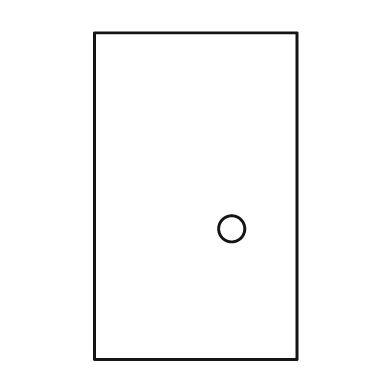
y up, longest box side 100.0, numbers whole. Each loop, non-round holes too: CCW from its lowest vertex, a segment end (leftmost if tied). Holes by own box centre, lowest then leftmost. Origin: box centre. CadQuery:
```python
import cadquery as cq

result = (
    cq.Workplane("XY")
    .moveTo(-31.0, -50.0)
    .lineTo(31.0, -50.0)
    .lineTo(31.0, 50.0)
    .lineTo(-31.0, 50.0)
    .close()
    .moveTo(11.0, -10.0)
    .circle(4.0)
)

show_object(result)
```